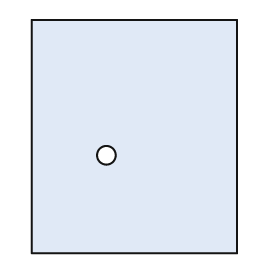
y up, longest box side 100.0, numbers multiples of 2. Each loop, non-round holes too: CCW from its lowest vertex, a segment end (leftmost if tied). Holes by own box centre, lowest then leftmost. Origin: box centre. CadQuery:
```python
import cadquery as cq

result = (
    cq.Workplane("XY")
    .moveTo(-44.0, -50.0)
    .lineTo(44.0, -50.0)
    .lineTo(44.0, 50.0)
    .lineTo(-44.0, 50.0)
    .close()
    .moveTo(-12.0, -8.0)
    .circle(4.0)
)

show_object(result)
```